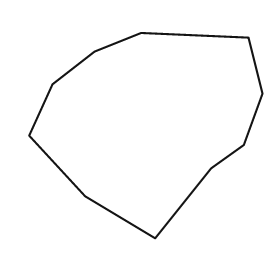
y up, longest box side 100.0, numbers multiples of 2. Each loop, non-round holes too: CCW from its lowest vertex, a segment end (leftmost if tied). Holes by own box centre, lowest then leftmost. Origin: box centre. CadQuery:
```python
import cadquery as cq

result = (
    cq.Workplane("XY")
    .moveTo(4.0, -44.0)
    .lineTo(28.0, -14.0)
    .lineTo(42.0, -4.0)
    .lineTo(50.0, 18.0)
    .lineTo(44.0, 42.0)
    .lineTo(-2.0, 44.0)
    .lineTo(-22.0, 36.0)
    .lineTo(-40.0, 22.0)
    .lineTo(-50.0, 0.0)
    .lineTo(-26.0, -26.0)
    .close()
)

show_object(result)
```